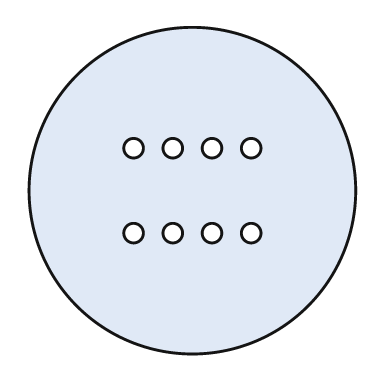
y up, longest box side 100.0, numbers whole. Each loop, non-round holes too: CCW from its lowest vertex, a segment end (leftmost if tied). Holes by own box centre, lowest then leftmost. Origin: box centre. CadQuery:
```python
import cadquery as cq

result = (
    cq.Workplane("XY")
    .moveTo(0.0, 0.0)
    .circle(50.0)
    .moveTo(-18.0, -13.0)
    .circle(3.0)
    .moveTo(-6.0, -13.0)
    .circle(3.0)
    .moveTo(6.0, -13.0)
    .circle(3.0)
    .moveTo(18.0, -13.0)
    .circle(3.0)
    .moveTo(-18.0, 13.0)
    .circle(3.0)
    .moveTo(-6.0, 13.0)
    .circle(3.0)
    .moveTo(6.0, 13.0)
    .circle(3.0)
    .moveTo(18.0, 13.0)
    .circle(3.0)
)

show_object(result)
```